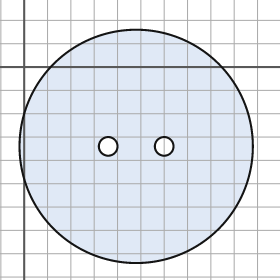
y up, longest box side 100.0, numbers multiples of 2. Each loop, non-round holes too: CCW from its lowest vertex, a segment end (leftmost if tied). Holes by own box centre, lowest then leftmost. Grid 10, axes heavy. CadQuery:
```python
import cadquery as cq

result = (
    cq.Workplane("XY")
    .moveTo(48.0, -34.0)
    .circle(50.0)
    .moveTo(36.0, -34.0)
    .circle(4.0)
    .moveTo(60.0, -34.0)
    .circle(4.0)
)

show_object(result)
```